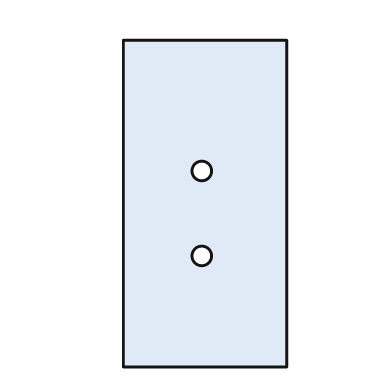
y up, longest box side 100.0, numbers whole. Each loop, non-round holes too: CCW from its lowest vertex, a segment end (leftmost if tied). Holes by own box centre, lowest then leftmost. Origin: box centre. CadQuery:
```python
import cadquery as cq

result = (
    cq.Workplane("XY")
    .moveTo(-25.0, -50.0)
    .lineTo(25.0, -50.0)
    .lineTo(25.0, 50.0)
    .lineTo(-25.0, 50.0)
    .close()
    .moveTo(-1.0, -16.0)
    .circle(3.0)
    .moveTo(-1.0, 10.0)
    .circle(3.0)
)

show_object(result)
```